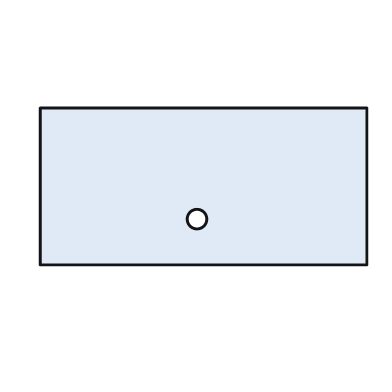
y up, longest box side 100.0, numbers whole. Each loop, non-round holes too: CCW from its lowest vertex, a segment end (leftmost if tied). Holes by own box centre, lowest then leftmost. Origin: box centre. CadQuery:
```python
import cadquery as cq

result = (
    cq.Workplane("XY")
    .moveTo(-50.0, -24.0)
    .lineTo(50.0, -24.0)
    .lineTo(50.0, 24.0)
    .lineTo(-50.0, 24.0)
    .close()
    .moveTo(-2.0, -10.0)
    .circle(3.0)
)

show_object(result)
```